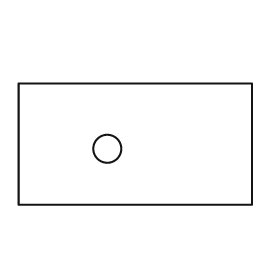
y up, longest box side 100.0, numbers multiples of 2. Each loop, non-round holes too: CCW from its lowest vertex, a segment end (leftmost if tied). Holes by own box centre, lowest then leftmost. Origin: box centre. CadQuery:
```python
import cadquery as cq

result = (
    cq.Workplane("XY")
    .moveTo(-50.0, -26.0)
    .lineTo(50.0, -26.0)
    .lineTo(50.0, 26.0)
    .lineTo(-50.0, 26.0)
    .close()
    .moveTo(-12.0, -2.0)
    .circle(6.0)
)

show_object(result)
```